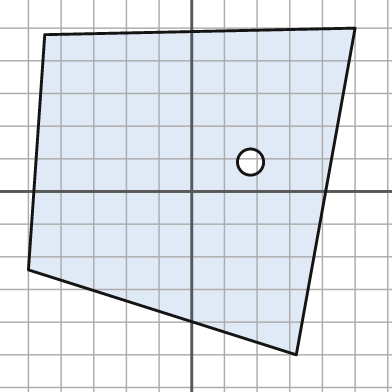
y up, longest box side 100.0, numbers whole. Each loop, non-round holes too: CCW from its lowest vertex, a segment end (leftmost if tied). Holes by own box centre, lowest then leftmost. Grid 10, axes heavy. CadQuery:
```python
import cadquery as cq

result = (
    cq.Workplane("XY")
    .moveTo(32.0, -50.0)
    .lineTo(50.0, 50.0)
    .lineTo(-45.0, 48.0)
    .lineTo(-50.0, -24.0)
    .close()
    .moveTo(18.0, 9.0)
    .circle(4.0)
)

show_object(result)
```